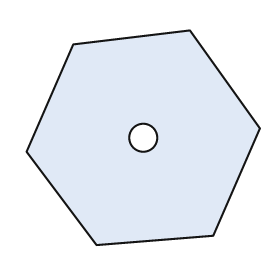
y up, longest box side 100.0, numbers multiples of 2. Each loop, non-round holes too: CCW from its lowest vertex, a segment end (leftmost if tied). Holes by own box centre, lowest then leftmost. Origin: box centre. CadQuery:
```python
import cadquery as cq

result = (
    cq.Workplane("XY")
    .moveTo(-20.0, -46.0)
    .lineTo(30.0, -42.0)
    .lineTo(50.0, 4.0)
    .lineTo(20.0, 46.0)
    .lineTo(-30.0, 40.0)
    .lineTo(-50.0, -6.0)
    .close()
    .moveTo(0.0, 0.0)
    .circle(6.0)
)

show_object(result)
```